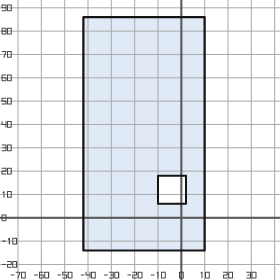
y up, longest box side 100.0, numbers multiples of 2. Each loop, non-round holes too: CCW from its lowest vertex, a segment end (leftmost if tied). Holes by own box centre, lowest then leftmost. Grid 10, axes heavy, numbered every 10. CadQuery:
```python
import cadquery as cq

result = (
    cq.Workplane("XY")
    .moveTo(-42.0, -14.0)
    .lineTo(10.0, -14.0)
    .lineTo(10.0, 86.0)
    .lineTo(-42.0, 86.0)
    .close()
    .moveTo(-10.0, 6.0)
    .lineTo(2.0, 6.0)
    .lineTo(2.0, 18.0)
    .lineTo(-10.0, 18.0)
    .close()
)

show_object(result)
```